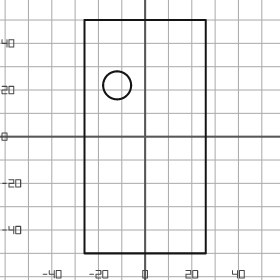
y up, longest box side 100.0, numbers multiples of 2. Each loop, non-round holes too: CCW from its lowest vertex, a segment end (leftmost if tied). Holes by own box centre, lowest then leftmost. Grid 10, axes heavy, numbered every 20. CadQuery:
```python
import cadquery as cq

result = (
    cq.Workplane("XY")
    .moveTo(-26.0, -50.0)
    .lineTo(26.0, -50.0)
    .lineTo(26.0, 50.0)
    .lineTo(-26.0, 50.0)
    .close()
    .moveTo(-12.0, 22.0)
    .circle(6.0)
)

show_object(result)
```